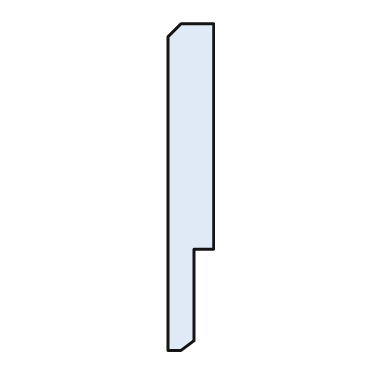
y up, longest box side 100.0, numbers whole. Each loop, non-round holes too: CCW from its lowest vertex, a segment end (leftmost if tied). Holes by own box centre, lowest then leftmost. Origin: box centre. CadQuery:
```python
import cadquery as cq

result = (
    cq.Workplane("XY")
    .moveTo(-7.0, -50.0)
    .lineTo(-3.0, -50.0)
    .lineTo(1.0, -47.0)
    .lineTo(1.0, -19.0)
    .lineTo(7.0, -19.0)
    .lineTo(7.0, 50.0)
    .lineTo(-3.0, 50.0)
    .lineTo(-7.0, 46.0)
    .close()
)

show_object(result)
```